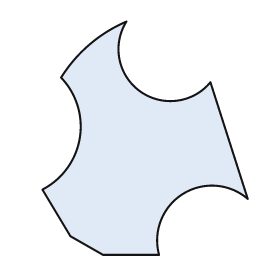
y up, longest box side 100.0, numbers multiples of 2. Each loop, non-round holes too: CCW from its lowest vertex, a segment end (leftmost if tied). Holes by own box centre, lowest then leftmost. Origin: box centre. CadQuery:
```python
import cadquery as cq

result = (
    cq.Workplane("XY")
    .moveTo(-18.0, -50.0)
    .lineTo(6.0, -50.0)
    .threePointArc((16.0, -24.0), (44.0, -26.0))
    .lineTo(28.0, 24.0)
    .threePointArc((-2.0, 20.0), (-8.0, 50.0))
    .threePointArc((-24.0, 40.0), (-36.0, 26.0))
    .threePointArc((-28.0, 0.0), (-44.0, -22.0))
    .lineTo(-32.0, -42.0)
    .close()
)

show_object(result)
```